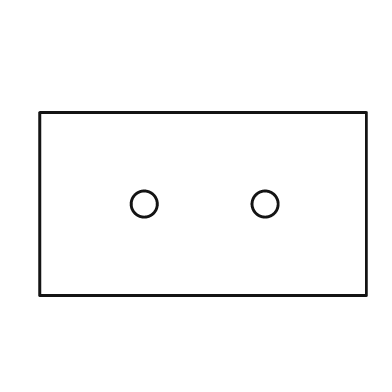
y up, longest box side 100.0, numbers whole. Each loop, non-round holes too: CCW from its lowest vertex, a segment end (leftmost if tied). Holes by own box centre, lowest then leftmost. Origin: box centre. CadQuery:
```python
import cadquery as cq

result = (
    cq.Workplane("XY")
    .moveTo(-50.0, -28.0)
    .lineTo(50.0, -28.0)
    .lineTo(50.0, 28.0)
    .lineTo(-50.0, 28.0)
    .close()
    .moveTo(-18.0, 0.0)
    .circle(4.0)
    .moveTo(19.0, 0.0)
    .circle(4.0)
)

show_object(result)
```